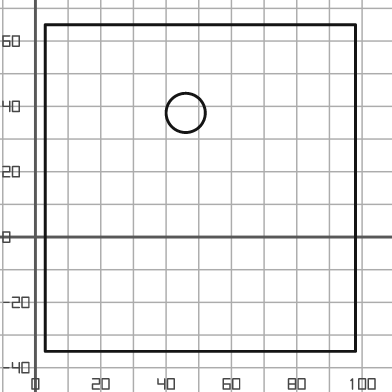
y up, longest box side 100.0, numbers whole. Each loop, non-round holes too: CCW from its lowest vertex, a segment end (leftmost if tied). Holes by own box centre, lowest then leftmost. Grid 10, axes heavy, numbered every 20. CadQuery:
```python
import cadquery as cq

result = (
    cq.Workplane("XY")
    .moveTo(3.0, -35.0)
    .lineTo(98.0, -35.0)
    .lineTo(98.0, 65.0)
    .lineTo(3.0, 65.0)
    .close()
    .moveTo(46.0, 38.0)
    .circle(6.0)
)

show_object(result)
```